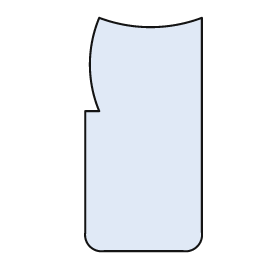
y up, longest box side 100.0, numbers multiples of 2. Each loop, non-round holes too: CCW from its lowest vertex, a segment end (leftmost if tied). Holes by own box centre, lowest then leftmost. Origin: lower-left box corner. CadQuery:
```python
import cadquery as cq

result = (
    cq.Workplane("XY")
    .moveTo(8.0, 0.0)
    .lineTo(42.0, 0.0)
    .threePointArc((48.0, 2.0), (50.0, 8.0))
    .lineTo(50.0, 100.0)
    .threePointArc((28.0, 96.0), (6.0, 100.0))
    .threePointArc((2.0, 80.0), (6.0, 60.0))
    .lineTo(0.0, 60.0)
    .lineTo(0.0, 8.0)
    .threePointArc((2.0, 2.0), (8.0, 0.0))
    .close()
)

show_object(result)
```